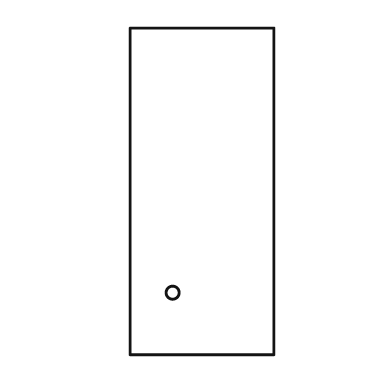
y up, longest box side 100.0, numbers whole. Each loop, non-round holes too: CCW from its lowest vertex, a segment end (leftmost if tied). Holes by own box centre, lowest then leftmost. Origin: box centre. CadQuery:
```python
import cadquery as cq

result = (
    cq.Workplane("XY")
    .moveTo(-22.0, -50.0)
    .lineTo(22.0, -50.0)
    .lineTo(22.0, 50.0)
    .lineTo(-22.0, 50.0)
    .close()
    .moveTo(-9.0, -31.0)
    .circle(2.0)
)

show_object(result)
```